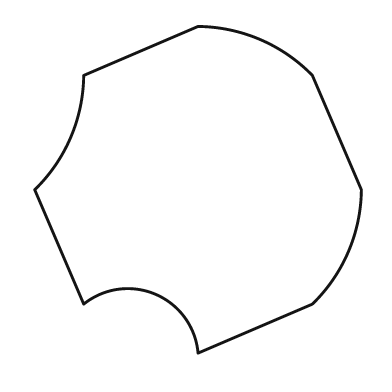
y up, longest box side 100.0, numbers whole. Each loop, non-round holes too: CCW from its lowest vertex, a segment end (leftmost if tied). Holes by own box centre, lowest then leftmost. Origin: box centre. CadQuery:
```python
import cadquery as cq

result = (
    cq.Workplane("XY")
    .moveTo(0.0, -50.0)
    .lineTo(35.0, -35.0)
    .threePointArc((46.0, -19.0), (50.0, 0.0))
    .lineTo(35.0, 35.0)
    .threePointArc((19.0, 46.0), (0.0, 50.0))
    .lineTo(-35.0, 35.0)
    .threePointArc((-39.0, 16.0), (-50.0, 0.0))
    .lineTo(-35.0, -35.0)
    .threePointArc((-13.0, -32.0), (0.0, -50.0))
    .close()
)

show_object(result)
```